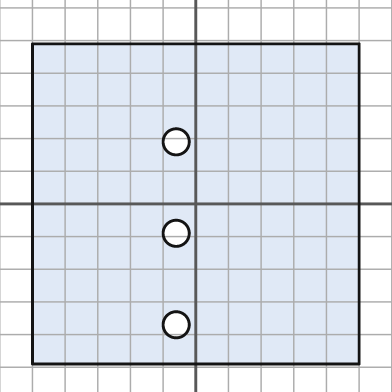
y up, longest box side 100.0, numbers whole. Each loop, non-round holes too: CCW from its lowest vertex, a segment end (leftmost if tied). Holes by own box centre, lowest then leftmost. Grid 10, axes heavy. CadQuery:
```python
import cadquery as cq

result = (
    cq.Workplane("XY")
    .moveTo(-50.0, -49.0)
    .lineTo(50.0, -49.0)
    .lineTo(50.0, 49.0)
    .lineTo(-50.0, 49.0)
    .close()
    .moveTo(-6.0, -37.0)
    .circle(4.0)
    .moveTo(-6.0, -9.0)
    .circle(4.0)
    .moveTo(-6.0, 19.0)
    .circle(4.0)
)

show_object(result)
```